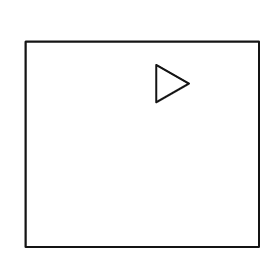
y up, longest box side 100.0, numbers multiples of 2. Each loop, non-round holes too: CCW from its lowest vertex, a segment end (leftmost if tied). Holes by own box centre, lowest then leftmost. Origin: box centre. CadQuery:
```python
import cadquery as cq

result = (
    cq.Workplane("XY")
    .moveTo(-50.0, -44.0)
    .lineTo(50.0, -44.0)
    .lineTo(50.0, 44.0)
    .lineTo(-50.0, 44.0)
    .close()
    .moveTo(6.0, 18.0)
    .lineTo(20.0, 26.0)
    .lineTo(6.0, 34.0)
    .close()
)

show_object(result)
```